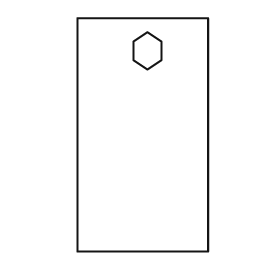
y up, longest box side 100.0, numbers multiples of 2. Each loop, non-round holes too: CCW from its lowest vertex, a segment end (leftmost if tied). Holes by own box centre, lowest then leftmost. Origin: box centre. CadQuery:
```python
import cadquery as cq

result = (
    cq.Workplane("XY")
    .moveTo(-28.0, -50.0)
    .lineTo(28.0, -50.0)
    .lineTo(28.0, 50.0)
    .lineTo(-28.0, 50.0)
    .close()
    .moveTo(2.0, 28.0)
    .lineTo(8.0, 32.0)
    .lineTo(8.0, 40.0)
    .lineTo(2.0, 44.0)
    .lineTo(-4.0, 40.0)
    .lineTo(-4.0, 32.0)
    .close()
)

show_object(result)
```